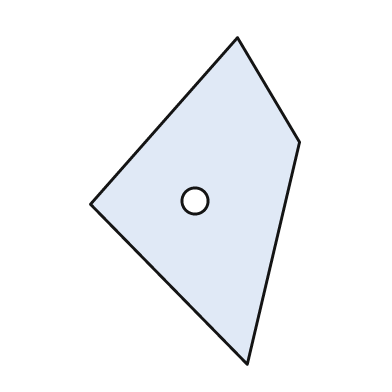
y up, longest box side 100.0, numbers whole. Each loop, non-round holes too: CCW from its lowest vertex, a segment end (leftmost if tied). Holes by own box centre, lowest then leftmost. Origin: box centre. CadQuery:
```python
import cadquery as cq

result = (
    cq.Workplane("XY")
    .moveTo(16.0, -50.0)
    .lineTo(32.0, 18.0)
    .lineTo(13.0, 50.0)
    .lineTo(-32.0, -1.0)
    .close()
    .moveTo(0.0, 0.0)
    .circle(4.0)
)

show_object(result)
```